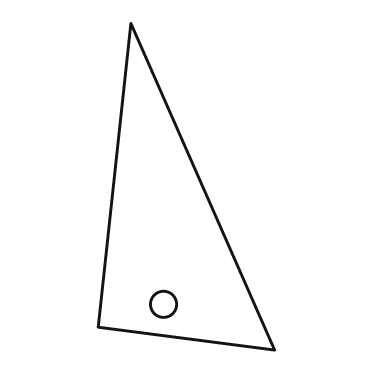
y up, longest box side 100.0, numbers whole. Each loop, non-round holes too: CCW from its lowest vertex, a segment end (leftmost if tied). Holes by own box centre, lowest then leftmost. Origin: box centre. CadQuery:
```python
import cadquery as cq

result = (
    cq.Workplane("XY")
    .moveTo(27.0, -50.0)
    .lineTo(-17.0, 50.0)
    .lineTo(-27.0, -43.0)
    .close()
    .moveTo(-7.0, -36.0)
    .circle(4.0)
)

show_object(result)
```